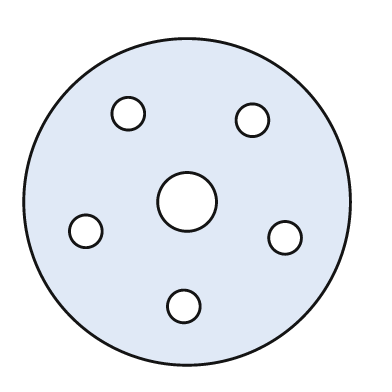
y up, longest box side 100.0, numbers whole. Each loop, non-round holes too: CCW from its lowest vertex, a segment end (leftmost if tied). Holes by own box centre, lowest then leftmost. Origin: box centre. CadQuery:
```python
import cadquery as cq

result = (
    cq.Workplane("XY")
    .moveTo(0.0, 0.0)
    .circle(50.0)
    .moveTo(-1.0, -32.0)
    .circle(5.0)
    .moveTo(30.0, -11.0)
    .circle(5.0)
    .moveTo(-31.0, -9.0)
    .circle(5.0)
    .moveTo(0.0, 0.0)
    .circle(9.0)
    .moveTo(20.0, 25.0)
    .circle(5.0)
    .moveTo(-18.0, 27.0)
    .circle(5.0)
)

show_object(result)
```